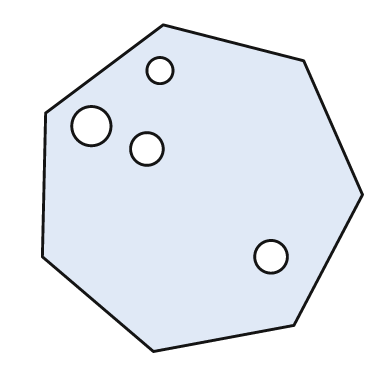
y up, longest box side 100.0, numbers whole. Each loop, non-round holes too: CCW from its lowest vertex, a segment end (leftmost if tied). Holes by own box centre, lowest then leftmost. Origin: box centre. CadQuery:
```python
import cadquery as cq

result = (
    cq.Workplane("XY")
    .moveTo(-15.0, -50.0)
    .lineTo(28.0, -42.0)
    .lineTo(49.0, -2.0)
    .lineTo(31.0, 39.0)
    .lineTo(-12.0, 50.0)
    .lineTo(-48.0, 23.0)
    .lineTo(-49.0, -21.0)
    .close()
    .moveTo(21.0, -21.0)
    .circle(5.0)
    .moveTo(-17.0, 12.0)
    .circle(5.0)
    .moveTo(-34.0, 19.0)
    .circle(6.0)
    .moveTo(-13.0, 36.0)
    .circle(4.0)
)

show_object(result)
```